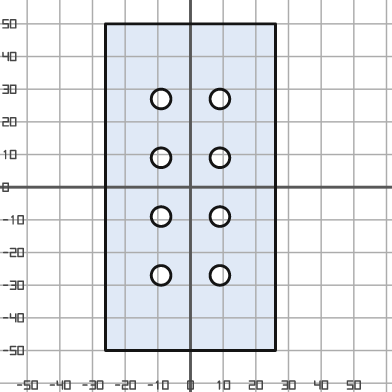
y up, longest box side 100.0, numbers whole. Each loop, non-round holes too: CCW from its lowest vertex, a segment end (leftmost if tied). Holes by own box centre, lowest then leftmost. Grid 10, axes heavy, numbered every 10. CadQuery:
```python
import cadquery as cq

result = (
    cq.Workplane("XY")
    .moveTo(-26.0, -50.0)
    .lineTo(26.0, -50.0)
    .lineTo(26.0, 50.0)
    .lineTo(-26.0, 50.0)
    .close()
    .moveTo(-9.0, -27.0)
    .circle(3.0)
    .moveTo(9.0, -27.0)
    .circle(3.0)
    .moveTo(-9.0, -9.0)
    .circle(3.0)
    .moveTo(9.0, -9.0)
    .circle(3.0)
    .moveTo(-9.0, 9.0)
    .circle(3.0)
    .moveTo(9.0, 9.0)
    .circle(3.0)
    .moveTo(-9.0, 27.0)
    .circle(3.0)
    .moveTo(9.0, 27.0)
    .circle(3.0)
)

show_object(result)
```